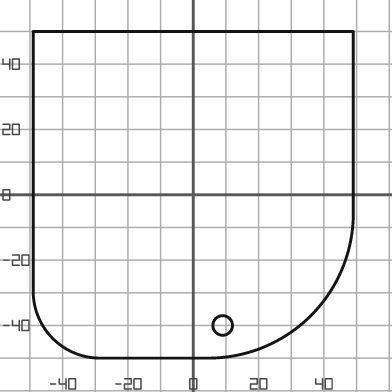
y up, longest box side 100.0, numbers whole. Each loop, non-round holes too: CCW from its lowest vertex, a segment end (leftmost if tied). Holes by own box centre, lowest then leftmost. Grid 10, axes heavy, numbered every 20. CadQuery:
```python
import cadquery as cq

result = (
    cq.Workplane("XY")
    .moveTo(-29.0, -50.0)
    .lineTo(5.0, -50.0)
    .threePointArc((36.0, -37.0), (49.0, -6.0))
    .lineTo(49.0, 50.0)
    .lineTo(-49.0, 50.0)
    .lineTo(-49.0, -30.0)
    .threePointArc((-43.0, -44.0), (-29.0, -50.0))
    .close()
    .moveTo(9.0, -40.0)
    .circle(3.0)
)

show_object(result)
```